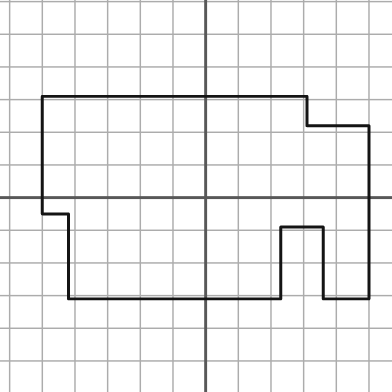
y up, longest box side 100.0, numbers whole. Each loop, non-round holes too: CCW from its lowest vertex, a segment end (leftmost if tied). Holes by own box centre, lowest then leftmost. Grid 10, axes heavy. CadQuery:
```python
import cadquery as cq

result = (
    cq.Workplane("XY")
    .moveTo(-42.0, -31.0)
    .lineTo(23.0, -31.0)
    .lineTo(23.0, -9.0)
    .lineTo(36.0, -9.0)
    .lineTo(36.0, -31.0)
    .lineTo(50.0, -31.0)
    .lineTo(50.0, 22.0)
    .lineTo(31.0, 22.0)
    .lineTo(31.0, 31.0)
    .lineTo(-50.0, 31.0)
    .lineTo(-50.0, -5.0)
    .lineTo(-42.0, -5.0)
    .close()
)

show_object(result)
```